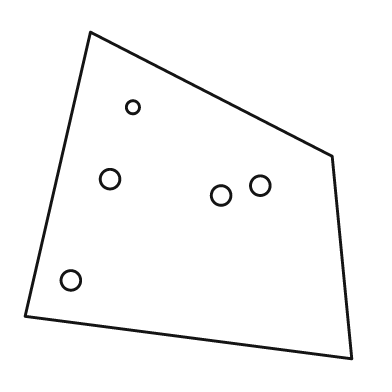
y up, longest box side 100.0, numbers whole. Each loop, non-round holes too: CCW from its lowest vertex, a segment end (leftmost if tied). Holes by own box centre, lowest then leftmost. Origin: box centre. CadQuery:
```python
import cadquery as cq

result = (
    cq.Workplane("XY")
    .moveTo(50.0, -50.0)
    .lineTo(44.0, 12.0)
    .lineTo(-30.0, 50.0)
    .lineTo(-50.0, -37.0)
    .close()
    .moveTo(-36.0, -26.0)
    .circle(3.0)
    .moveTo(10.0, 0.0)
    .circle(3.0)
    .moveTo(22.0, 3.0)
    .circle(3.0)
    .moveTo(-24.0, 5.0)
    .circle(3.0)
    .moveTo(-17.0, 27.0)
    .circle(2.0)
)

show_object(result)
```